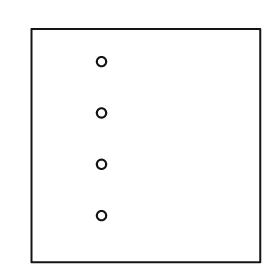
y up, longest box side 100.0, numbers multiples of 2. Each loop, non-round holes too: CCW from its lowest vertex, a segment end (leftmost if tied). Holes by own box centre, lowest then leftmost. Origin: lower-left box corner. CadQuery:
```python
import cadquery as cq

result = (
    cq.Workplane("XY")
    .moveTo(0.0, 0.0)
    .lineTo(98.0, 0.0)
    .lineTo(98.0, 100.0)
    .lineTo(0.0, 100.0)
    .close()
    .moveTo(30.0, 20.0)
    .circle(2.0)
    .moveTo(30.0, 42.0)
    .circle(2.0)
    .moveTo(30.0, 64.0)
    .circle(2.0)
    .moveTo(30.0, 86.0)
    .circle(2.0)
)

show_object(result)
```